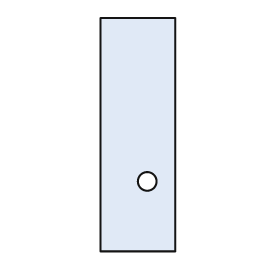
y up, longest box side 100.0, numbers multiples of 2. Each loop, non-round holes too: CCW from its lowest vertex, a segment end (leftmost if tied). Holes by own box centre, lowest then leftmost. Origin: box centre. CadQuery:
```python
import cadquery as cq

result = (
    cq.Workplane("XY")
    .moveTo(-16.0, -50.0)
    .lineTo(16.0, -50.0)
    .lineTo(16.0, 50.0)
    .lineTo(-16.0, 50.0)
    .close()
    .moveTo(4.0, -20.0)
    .circle(4.0)
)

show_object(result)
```